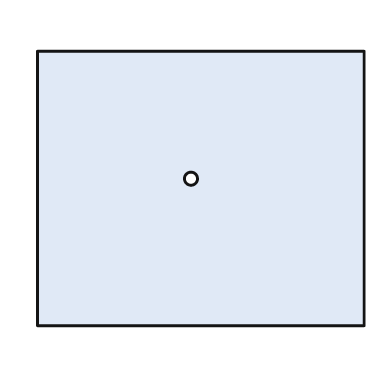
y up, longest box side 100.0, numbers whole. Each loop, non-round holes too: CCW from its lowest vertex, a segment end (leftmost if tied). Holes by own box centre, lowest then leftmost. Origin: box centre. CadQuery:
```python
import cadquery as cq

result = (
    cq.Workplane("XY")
    .moveTo(-50.0, -42.0)
    .lineTo(50.0, -42.0)
    .lineTo(50.0, 42.0)
    .lineTo(-50.0, 42.0)
    .close()
    .moveTo(-3.0, 3.0)
    .circle(2.0)
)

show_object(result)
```